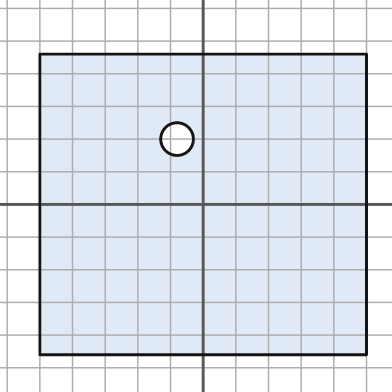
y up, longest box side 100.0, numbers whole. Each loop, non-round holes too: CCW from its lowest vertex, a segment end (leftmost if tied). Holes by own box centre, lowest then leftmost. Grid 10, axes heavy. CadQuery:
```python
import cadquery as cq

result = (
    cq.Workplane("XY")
    .moveTo(-50.0, -46.0)
    .lineTo(50.0, -46.0)
    .lineTo(50.0, 46.0)
    .lineTo(-50.0, 46.0)
    .close()
    .moveTo(-8.0, 20.0)
    .circle(5.0)
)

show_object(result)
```